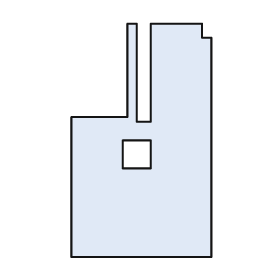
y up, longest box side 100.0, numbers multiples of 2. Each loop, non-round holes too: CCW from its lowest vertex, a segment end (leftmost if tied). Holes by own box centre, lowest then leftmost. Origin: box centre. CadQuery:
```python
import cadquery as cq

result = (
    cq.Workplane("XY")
    .moveTo(-30.0, -50.0)
    .lineTo(30.0, -50.0)
    .lineTo(30.0, 44.0)
    .lineTo(26.0, 44.0)
    .lineTo(26.0, 50.0)
    .lineTo(4.0, 50.0)
    .lineTo(4.0, 8.0)
    .lineTo(-2.0, 8.0)
    .lineTo(-2.0, 50.0)
    .lineTo(-6.0, 50.0)
    .lineTo(-6.0, 10.0)
    .lineTo(-30.0, 10.0)
    .close()
    .moveTo(-8.0, -12.0)
    .lineTo(4.0, -12.0)
    .lineTo(4.0, 0.0)
    .lineTo(-8.0, 0.0)
    .close()
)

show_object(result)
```